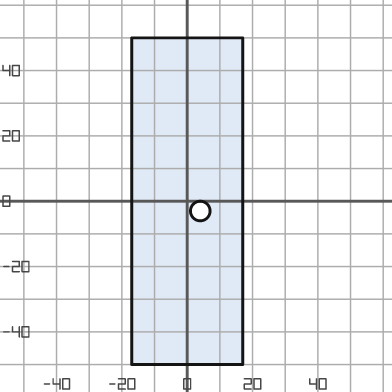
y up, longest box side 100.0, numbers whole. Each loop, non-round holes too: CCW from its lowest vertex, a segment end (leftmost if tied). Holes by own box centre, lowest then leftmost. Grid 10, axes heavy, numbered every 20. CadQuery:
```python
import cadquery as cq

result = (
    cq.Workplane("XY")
    .moveTo(-17.0, -50.0)
    .lineTo(17.0, -50.0)
    .lineTo(17.0, 50.0)
    .lineTo(-17.0, 50.0)
    .close()
    .moveTo(4.0, -3.0)
    .circle(3.0)
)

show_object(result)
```